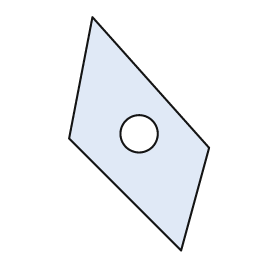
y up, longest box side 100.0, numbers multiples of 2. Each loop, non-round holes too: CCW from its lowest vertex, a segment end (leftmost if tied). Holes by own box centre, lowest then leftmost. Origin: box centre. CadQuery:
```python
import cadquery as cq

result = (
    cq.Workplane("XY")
    .moveTo(18.0, -50.0)
    .lineTo(30.0, -6.0)
    .lineTo(-20.0, 50.0)
    .lineTo(-30.0, -2.0)
    .close()
    .moveTo(0.0, 0.0)
    .circle(8.0)
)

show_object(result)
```